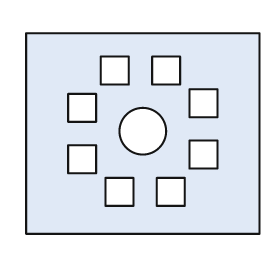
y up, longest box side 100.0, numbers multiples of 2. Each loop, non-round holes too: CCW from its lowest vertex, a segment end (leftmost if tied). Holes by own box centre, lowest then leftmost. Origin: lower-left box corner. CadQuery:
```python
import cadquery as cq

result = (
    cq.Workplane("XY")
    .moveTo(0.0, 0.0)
    .lineTo(100.0, 0.0)
    .lineTo(100.0, 86.0)
    .lineTo(0.0, 86.0)
    .close()
    .moveTo(34.0, 12.0)
    .lineTo(46.0, 12.0)
    .lineTo(46.0, 24.0)
    .lineTo(34.0, 24.0)
    .close()
    .moveTo(56.0, 12.0)
    .lineTo(68.0, 12.0)
    .lineTo(68.0, 24.0)
    .lineTo(56.0, 24.0)
    .close()
    .moveTo(18.0, 26.0)
    .lineTo(30.0, 26.0)
    .lineTo(30.0, 38.0)
    .lineTo(18.0, 38.0)
    .close()
    .moveTo(70.0, 28.0)
    .lineTo(82.0, 28.0)
    .lineTo(82.0, 40.0)
    .lineTo(70.0, 40.0)
    .close()
    .moveTo(50.0, 44.0)
    .circle(10.0)
    .moveTo(18.0, 48.0)
    .lineTo(30.0, 48.0)
    .lineTo(30.0, 60.0)
    .lineTo(18.0, 60.0)
    .close()
    .moveTo(70.0, 50.0)
    .lineTo(82.0, 50.0)
    .lineTo(82.0, 62.0)
    .lineTo(70.0, 62.0)
    .close()
    .moveTo(32.0, 64.0)
    .lineTo(44.0, 64.0)
    .lineTo(44.0, 76.0)
    .lineTo(32.0, 76.0)
    .close()
    .moveTo(54.0, 64.0)
    .lineTo(66.0, 64.0)
    .lineTo(66.0, 76.0)
    .lineTo(54.0, 76.0)
    .close()
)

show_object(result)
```